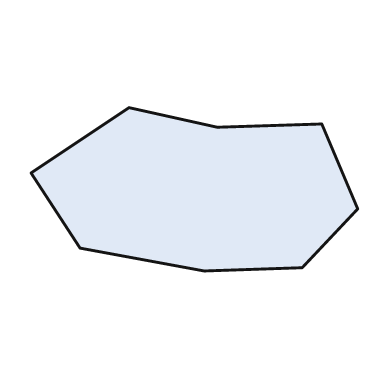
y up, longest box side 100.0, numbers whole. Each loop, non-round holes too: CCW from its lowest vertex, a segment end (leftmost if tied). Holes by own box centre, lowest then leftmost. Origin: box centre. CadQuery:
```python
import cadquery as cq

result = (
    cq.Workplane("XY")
    .moveTo(3.0, -25.0)
    .lineTo(33.0, -24.0)
    .lineTo(50.0, -6.0)
    .lineTo(39.0, 20.0)
    .lineTo(7.0, 19.0)
    .lineTo(-20.0, 25.0)
    .lineTo(-50.0, 5.0)
    .lineTo(-35.0, -18.0)
    .close()
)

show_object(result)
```